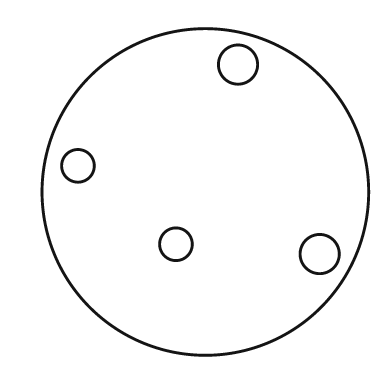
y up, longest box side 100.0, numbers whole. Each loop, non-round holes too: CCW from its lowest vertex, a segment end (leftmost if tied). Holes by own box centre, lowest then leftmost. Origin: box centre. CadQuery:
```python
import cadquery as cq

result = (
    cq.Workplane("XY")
    .moveTo(0.0, 0.0)
    .circle(50.0)
    .moveTo(35.0, -19.0)
    .circle(6.0)
    .moveTo(-9.0, -16.0)
    .circle(5.0)
    .moveTo(-39.0, 8.0)
    .circle(5.0)
    .moveTo(10.0, 39.0)
    .circle(6.0)
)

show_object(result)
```